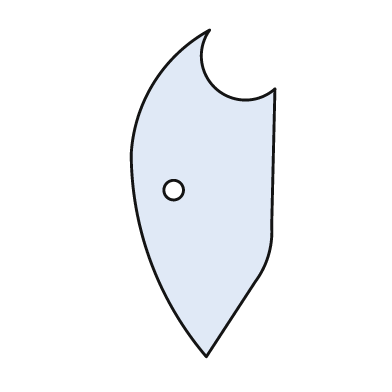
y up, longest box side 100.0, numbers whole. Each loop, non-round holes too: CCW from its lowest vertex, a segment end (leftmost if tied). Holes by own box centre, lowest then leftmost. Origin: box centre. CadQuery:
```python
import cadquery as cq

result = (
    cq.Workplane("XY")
    .moveTo(1.0, -50.0)
    .lineTo(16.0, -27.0)
    .threePointArc((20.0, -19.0), (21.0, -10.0))
    .lineTo(22.0, 32.0)
    .threePointArc((4.0, 32.0), (2.0, 50.0))
    .threePointArc((-15.0, 34.0), (-22.0, 12.0))
    .threePointArc((-16.0, -21.0), (1.0, -50.0))
    .close()
    .moveTo(-9.0, 1.0)
    .circle(3.0)
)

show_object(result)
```